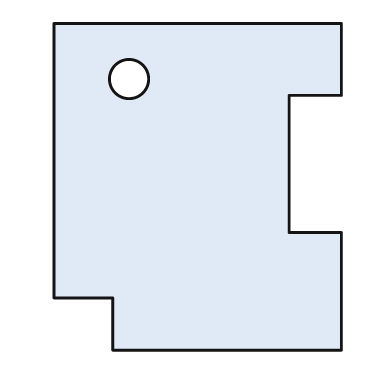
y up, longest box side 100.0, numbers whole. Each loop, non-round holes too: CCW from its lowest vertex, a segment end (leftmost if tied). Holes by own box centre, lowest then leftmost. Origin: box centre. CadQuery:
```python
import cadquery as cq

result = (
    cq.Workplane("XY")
    .moveTo(-26.0, -50.0)
    .lineTo(44.0, -50.0)
    .lineTo(44.0, -14.0)
    .lineTo(28.0, -14.0)
    .lineTo(28.0, 28.0)
    .lineTo(44.0, 28.0)
    .lineTo(44.0, 50.0)
    .lineTo(-44.0, 50.0)
    .lineTo(-44.0, -34.0)
    .lineTo(-26.0, -34.0)
    .close()
    .moveTo(-21.0, 33.0)
    .circle(6.0)
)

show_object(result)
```